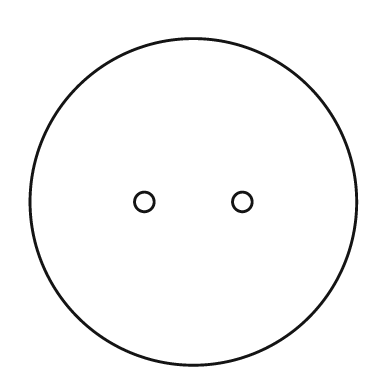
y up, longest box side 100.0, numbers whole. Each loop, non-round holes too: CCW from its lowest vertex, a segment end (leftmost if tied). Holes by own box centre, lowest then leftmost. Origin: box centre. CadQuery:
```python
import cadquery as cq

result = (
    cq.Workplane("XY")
    .moveTo(0.0, 0.0)
    .circle(50.0)
    .moveTo(-15.0, 0.0)
    .circle(3.0)
    .moveTo(15.0, 0.0)
    .circle(3.0)
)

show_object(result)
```